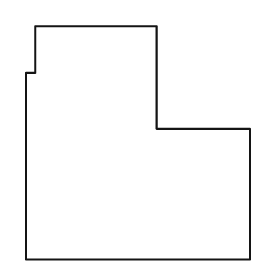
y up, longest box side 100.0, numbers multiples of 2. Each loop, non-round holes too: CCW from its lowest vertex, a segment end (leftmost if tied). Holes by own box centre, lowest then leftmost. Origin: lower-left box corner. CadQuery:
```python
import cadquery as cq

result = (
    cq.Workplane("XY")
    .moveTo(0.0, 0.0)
    .lineTo(96.0, 0.0)
    .lineTo(96.0, 56.0)
    .lineTo(56.0, 56.0)
    .lineTo(56.0, 100.0)
    .lineTo(4.0, 100.0)
    .lineTo(4.0, 80.0)
    .lineTo(0.0, 80.0)
    .close()
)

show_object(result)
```